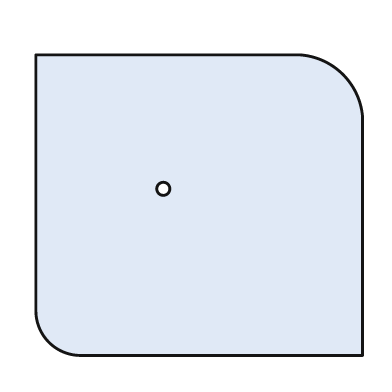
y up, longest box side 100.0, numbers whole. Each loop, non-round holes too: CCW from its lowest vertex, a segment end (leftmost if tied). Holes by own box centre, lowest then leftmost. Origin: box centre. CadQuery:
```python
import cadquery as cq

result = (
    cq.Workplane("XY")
    .moveTo(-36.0, -46.0)
    .lineTo(50.0, -46.0)
    .lineTo(50.0, 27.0)
    .threePointArc((44.0, 40.0), (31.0, 46.0))
    .lineTo(-50.0, 46.0)
    .lineTo(-50.0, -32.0)
    .threePointArc((-46.0, -42.0), (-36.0, -46.0))
    .close()
    .moveTo(-11.0, 5.0)
    .circle(2.0)
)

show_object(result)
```